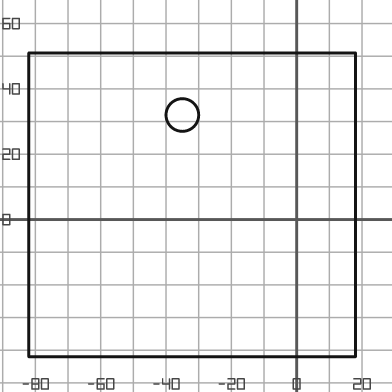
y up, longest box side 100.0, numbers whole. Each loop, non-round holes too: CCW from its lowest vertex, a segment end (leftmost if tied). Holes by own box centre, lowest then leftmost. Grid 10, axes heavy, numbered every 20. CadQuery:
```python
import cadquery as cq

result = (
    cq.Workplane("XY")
    .moveTo(-82.0, -42.0)
    .lineTo(18.0, -42.0)
    .lineTo(18.0, 51.0)
    .lineTo(-82.0, 51.0)
    .close()
    .moveTo(-35.0, 32.0)
    .circle(5.0)
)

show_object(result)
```